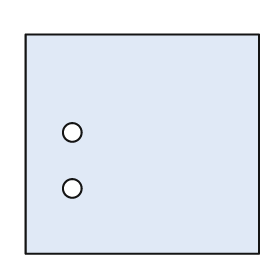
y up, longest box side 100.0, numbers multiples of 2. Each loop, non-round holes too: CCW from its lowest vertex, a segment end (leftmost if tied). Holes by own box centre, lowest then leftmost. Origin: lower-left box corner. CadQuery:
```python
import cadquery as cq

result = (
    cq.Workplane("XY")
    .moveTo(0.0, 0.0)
    .lineTo(100.0, 0.0)
    .lineTo(100.0, 94.0)
    .lineTo(0.0, 94.0)
    .close()
    .moveTo(20.0, 28.0)
    .circle(4.0)
    .moveTo(20.0, 52.0)
    .circle(4.0)
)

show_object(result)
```